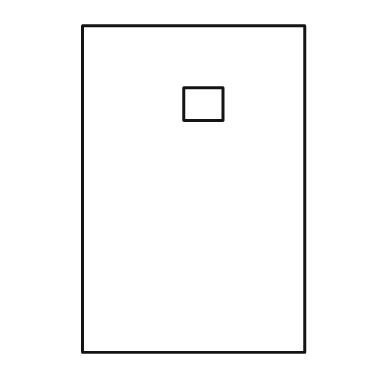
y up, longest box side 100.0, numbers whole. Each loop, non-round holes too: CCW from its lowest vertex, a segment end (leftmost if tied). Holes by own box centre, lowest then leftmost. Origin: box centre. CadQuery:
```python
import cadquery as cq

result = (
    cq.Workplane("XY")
    .moveTo(-34.0, -50.0)
    .lineTo(34.0, -50.0)
    .lineTo(34.0, 50.0)
    .lineTo(-34.0, 50.0)
    .close()
    .moveTo(-3.0, 21.0)
    .lineTo(9.0, 21.0)
    .lineTo(9.0, 31.0)
    .lineTo(-3.0, 31.0)
    .close()
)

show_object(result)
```